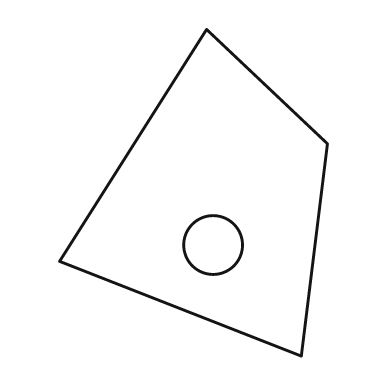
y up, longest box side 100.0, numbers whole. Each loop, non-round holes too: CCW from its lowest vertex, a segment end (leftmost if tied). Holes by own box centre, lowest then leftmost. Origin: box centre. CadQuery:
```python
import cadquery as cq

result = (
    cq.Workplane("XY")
    .moveTo(33.0, -50.0)
    .lineTo(41.0, 15.0)
    .lineTo(4.0, 50.0)
    .lineTo(-41.0, -21.0)
    .close()
    .moveTo(6.0, -16.0)
    .circle(9.0)
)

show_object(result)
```